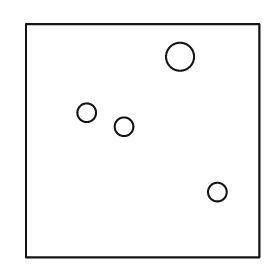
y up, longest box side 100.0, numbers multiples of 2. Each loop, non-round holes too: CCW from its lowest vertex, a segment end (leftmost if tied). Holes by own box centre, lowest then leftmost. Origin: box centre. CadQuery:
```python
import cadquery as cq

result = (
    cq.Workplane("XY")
    .moveTo(-50.0, -50.0)
    .lineTo(50.0, -50.0)
    .lineTo(50.0, 50.0)
    .lineTo(-50.0, 50.0)
    .close()
    .moveTo(32.0, -22.0)
    .circle(4.0)
    .moveTo(-8.0, 6.0)
    .circle(4.0)
    .moveTo(-24.0, 12.0)
    .circle(4.0)
    .moveTo(16.0, 36.0)
    .circle(6.0)
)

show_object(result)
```